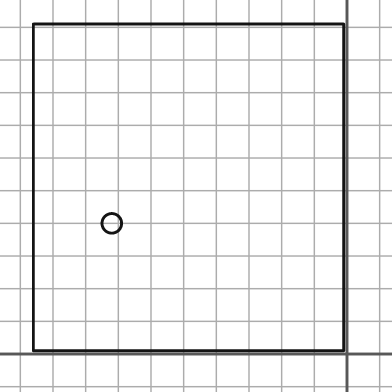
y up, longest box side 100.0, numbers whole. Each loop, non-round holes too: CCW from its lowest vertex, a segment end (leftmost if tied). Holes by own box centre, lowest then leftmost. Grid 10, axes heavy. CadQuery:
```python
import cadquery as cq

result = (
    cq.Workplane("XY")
    .moveTo(-96.0, 1.0)
    .lineTo(-1.0, 1.0)
    .lineTo(-1.0, 101.0)
    .lineTo(-96.0, 101.0)
    .close()
    .moveTo(-72.0, 40.0)
    .circle(3.0)
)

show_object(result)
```